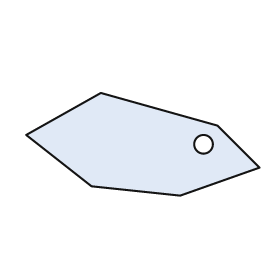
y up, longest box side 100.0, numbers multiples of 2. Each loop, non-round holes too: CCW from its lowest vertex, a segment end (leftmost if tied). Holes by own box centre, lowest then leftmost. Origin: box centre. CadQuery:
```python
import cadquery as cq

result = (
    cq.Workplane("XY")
    .moveTo(16.0, -22.0)
    .lineTo(50.0, -10.0)
    .lineTo(32.0, 8.0)
    .lineTo(-18.0, 22.0)
    .lineTo(-50.0, 4.0)
    .lineTo(-22.0, -18.0)
    .close()
    .moveTo(26.0, 0.0)
    .circle(4.0)
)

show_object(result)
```